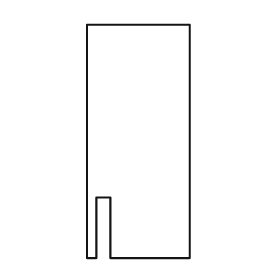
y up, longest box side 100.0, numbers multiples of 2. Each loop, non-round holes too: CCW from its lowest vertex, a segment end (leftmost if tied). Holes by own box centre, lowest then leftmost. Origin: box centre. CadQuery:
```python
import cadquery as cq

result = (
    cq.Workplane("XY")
    .moveTo(-22.0, -50.0)
    .lineTo(-18.0, -50.0)
    .lineTo(-18.0, -24.0)
    .lineTo(-12.0, -24.0)
    .lineTo(-12.0, -50.0)
    .lineTo(22.0, -50.0)
    .lineTo(22.0, 50.0)
    .lineTo(-22.0, 50.0)
    .close()
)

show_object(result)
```